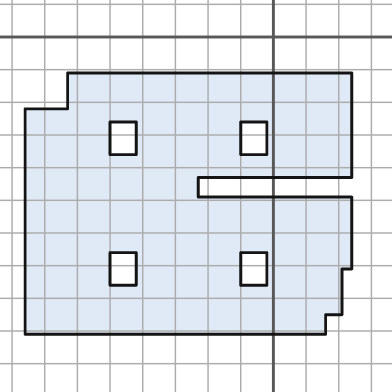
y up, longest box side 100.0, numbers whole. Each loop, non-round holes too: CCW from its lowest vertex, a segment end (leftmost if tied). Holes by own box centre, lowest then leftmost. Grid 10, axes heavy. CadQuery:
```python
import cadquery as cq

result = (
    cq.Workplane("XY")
    .moveTo(-76.0, -91.0)
    .lineTo(16.0, -91.0)
    .lineTo(16.0, -85.0)
    .lineTo(21.0, -85.0)
    .lineTo(21.0, -71.0)
    .lineTo(24.0, -71.0)
    .lineTo(24.0, -49.0)
    .lineTo(-23.0, -49.0)
    .lineTo(-23.0, -43.0)
    .lineTo(24.0, -43.0)
    .lineTo(24.0, -11.0)
    .lineTo(-63.0, -11.0)
    .lineTo(-63.0, -22.0)
    .lineTo(-76.0, -22.0)
    .close()
    .moveTo(-50.0, -76.0)
    .lineTo(-42.0, -76.0)
    .lineTo(-42.0, -66.0)
    .lineTo(-50.0, -66.0)
    .close()
    .moveTo(-10.0, -76.0)
    .lineTo(-2.0, -76.0)
    .lineTo(-2.0, -66.0)
    .lineTo(-10.0, -66.0)
    .close()
    .moveTo(-50.0, -36.0)
    .lineTo(-42.0, -36.0)
    .lineTo(-42.0, -26.0)
    .lineTo(-50.0, -26.0)
    .close()
    .moveTo(-10.0, -36.0)
    .lineTo(-2.0, -36.0)
    .lineTo(-2.0, -26.0)
    .lineTo(-10.0, -26.0)
    .close()
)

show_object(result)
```